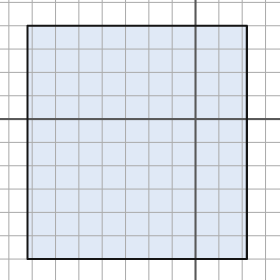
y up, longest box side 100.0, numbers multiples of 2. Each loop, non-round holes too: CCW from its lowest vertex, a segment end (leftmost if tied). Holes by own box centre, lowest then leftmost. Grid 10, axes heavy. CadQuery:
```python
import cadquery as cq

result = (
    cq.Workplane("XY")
    .moveTo(-72.0, -60.0)
    .lineTo(22.0, -60.0)
    .lineTo(22.0, 40.0)
    .lineTo(-72.0, 40.0)
    .close()
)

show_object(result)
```